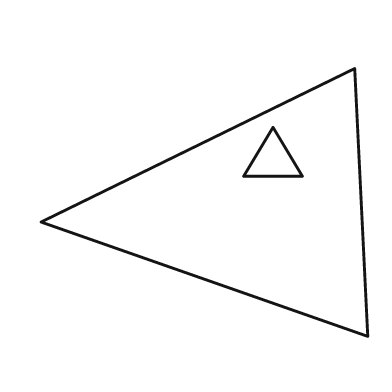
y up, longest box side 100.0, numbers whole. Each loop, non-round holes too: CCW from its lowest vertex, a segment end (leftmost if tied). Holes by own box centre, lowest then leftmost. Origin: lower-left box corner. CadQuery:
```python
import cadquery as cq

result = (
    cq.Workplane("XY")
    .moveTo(100.0, 0.0)
    .lineTo(96.0, 82.0)
    .lineTo(0.0, 35.0)
    .close()
    .moveTo(62.0, 49.0)
    .lineTo(80.0, 49.0)
    .lineTo(71.0, 64.0)
    .close()
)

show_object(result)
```